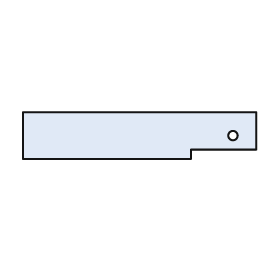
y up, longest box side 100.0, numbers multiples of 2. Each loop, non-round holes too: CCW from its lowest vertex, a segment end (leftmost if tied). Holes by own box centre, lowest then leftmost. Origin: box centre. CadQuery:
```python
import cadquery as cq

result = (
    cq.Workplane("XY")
    .moveTo(-50.0, -10.0)
    .lineTo(22.0, -10.0)
    .lineTo(22.0, -6.0)
    .lineTo(50.0, -6.0)
    .lineTo(50.0, 10.0)
    .lineTo(-50.0, 10.0)
    .close()
    .moveTo(40.0, 0.0)
    .circle(2.0)
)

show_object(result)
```